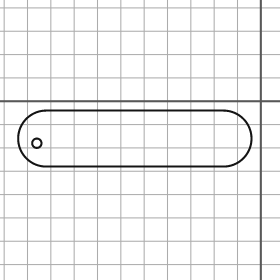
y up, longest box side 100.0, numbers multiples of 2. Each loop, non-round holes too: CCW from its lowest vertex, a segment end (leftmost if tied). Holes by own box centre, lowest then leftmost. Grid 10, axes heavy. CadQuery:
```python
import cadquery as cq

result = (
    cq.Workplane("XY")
    .moveTo(-92.0, -28.0)
    .lineTo(-16.0, -28.0)
    .threePointArc((-4.0, -16.0), (-16.0, -4.0))
    .lineTo(-92.0, -4.0)
    .threePointArc((-104.0, -16.0), (-92.0, -28.0))
    .close()
    .moveTo(-96.0, -18.0)
    .circle(2.0)
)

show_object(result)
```